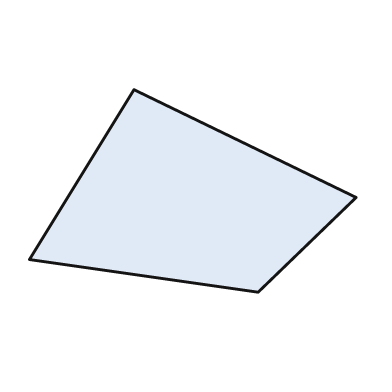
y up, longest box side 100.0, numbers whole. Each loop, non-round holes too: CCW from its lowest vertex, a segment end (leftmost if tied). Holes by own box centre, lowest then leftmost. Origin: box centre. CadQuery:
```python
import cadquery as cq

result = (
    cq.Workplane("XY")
    .moveTo(20.0, -31.0)
    .lineTo(50.0, -2.0)
    .lineTo(-18.0, 31.0)
    .lineTo(-50.0, -21.0)
    .close()
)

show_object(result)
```